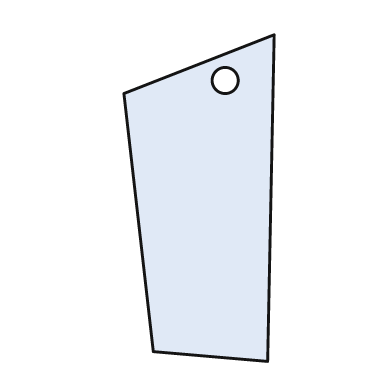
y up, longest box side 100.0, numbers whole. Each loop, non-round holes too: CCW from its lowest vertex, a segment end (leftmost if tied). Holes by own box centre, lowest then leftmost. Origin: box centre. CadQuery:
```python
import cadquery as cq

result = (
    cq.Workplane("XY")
    .moveTo(21.0, -50.0)
    .lineTo(23.0, 50.0)
    .lineTo(-23.0, 32.0)
    .lineTo(-14.0, -47.0)
    .close()
    .moveTo(8.0, 36.0)
    .circle(4.0)
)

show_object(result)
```